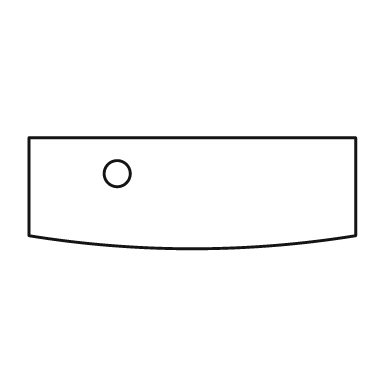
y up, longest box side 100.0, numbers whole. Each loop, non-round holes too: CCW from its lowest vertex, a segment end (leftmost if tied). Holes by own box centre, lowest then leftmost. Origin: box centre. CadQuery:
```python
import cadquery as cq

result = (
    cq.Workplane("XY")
    .moveTo(-50.0, -13.0)
    .threePointArc((0.0, -17.0), (50.0, -13.0))
    .lineTo(50.0, 17.0)
    .lineTo(-50.0, 17.0)
    .close()
    .moveTo(-23.0, 6.0)
    .circle(4.0)
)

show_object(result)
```